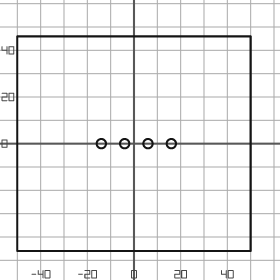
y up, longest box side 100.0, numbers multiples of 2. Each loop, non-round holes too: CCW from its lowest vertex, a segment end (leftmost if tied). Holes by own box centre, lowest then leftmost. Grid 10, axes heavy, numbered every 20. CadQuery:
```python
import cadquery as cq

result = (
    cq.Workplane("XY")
    .moveTo(-50.0, -46.0)
    .lineTo(50.0, -46.0)
    .lineTo(50.0, 46.0)
    .lineTo(-50.0, 46.0)
    .close()
    .moveTo(-14.0, 0.0)
    .circle(2.0)
    .moveTo(-4.0, 0.0)
    .circle(2.0)
    .moveTo(6.0, 0.0)
    .circle(2.0)
    .moveTo(16.0, 0.0)
    .circle(2.0)
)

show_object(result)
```